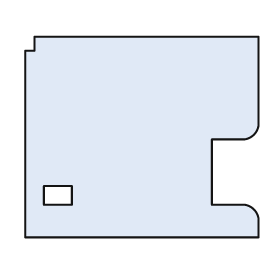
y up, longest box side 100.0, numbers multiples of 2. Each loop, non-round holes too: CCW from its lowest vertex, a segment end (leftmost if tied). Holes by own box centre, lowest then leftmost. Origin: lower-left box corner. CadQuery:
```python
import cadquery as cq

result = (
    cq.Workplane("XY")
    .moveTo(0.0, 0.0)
    .lineTo(100.0, 0.0)
    .lineTo(100.0, 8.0)
    .threePointArc((98.0, 12.0), (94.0, 14.0))
    .lineTo(80.0, 14.0)
    .lineTo(80.0, 42.0)
    .lineTo(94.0, 42.0)
    .threePointArc((98.0, 44.0), (100.0, 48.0))
    .lineTo(100.0, 86.0)
    .lineTo(4.0, 86.0)
    .lineTo(4.0, 80.0)
    .lineTo(0.0, 80.0)
    .close()
    .moveTo(8.0, 14.0)
    .lineTo(20.0, 14.0)
    .lineTo(20.0, 22.0)
    .lineTo(8.0, 22.0)
    .close()
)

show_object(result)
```